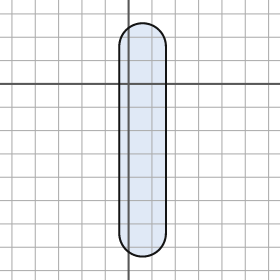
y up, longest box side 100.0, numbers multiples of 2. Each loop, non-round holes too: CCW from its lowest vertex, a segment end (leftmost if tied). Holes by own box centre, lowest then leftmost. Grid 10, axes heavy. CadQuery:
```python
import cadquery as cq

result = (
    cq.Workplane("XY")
    .moveTo(-4.0, -64.0)
    .threePointArc((6.0, -74.0), (16.0, -64.0))
    .lineTo(16.0, 16.0)
    .threePointArc((6.0, 26.0), (-4.0, 16.0))
    .close()
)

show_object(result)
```